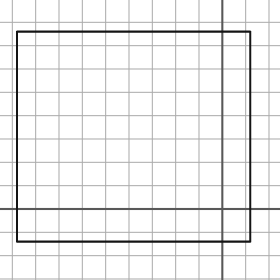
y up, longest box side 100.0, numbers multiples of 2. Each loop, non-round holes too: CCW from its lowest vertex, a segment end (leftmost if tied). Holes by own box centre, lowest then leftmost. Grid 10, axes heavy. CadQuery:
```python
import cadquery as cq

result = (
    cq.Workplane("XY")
    .moveTo(-88.0, -14.0)
    .lineTo(12.0, -14.0)
    .lineTo(12.0, 76.0)
    .lineTo(-88.0, 76.0)
    .close()
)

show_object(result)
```